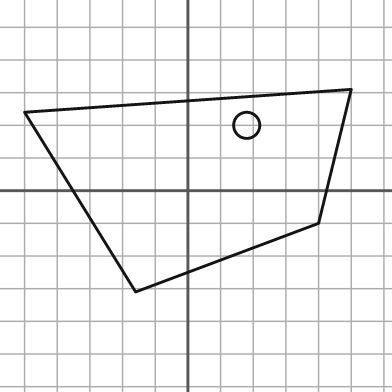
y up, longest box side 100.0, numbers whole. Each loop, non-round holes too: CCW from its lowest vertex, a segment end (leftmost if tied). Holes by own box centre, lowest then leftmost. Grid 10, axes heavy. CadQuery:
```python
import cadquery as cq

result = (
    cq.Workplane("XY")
    .moveTo(-16.0, -31.0)
    .lineTo(40.0, -10.0)
    .lineTo(50.0, 31.0)
    .lineTo(-50.0, 24.0)
    .close()
    .moveTo(18.0, 20.0)
    .circle(4.0)
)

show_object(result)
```